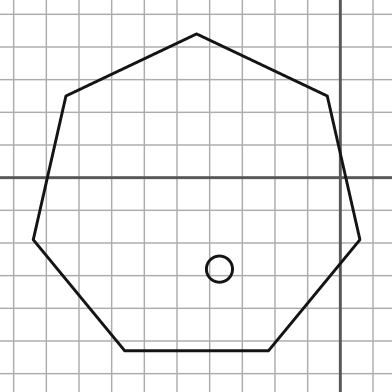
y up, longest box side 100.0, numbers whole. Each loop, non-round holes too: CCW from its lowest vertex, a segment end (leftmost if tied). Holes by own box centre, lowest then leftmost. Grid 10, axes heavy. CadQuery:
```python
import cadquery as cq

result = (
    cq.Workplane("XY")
    .moveTo(-66.0, -53.0)
    .lineTo(-22.0, -53.0)
    .lineTo(6.0, -19.0)
    .lineTo(-4.0, 25.0)
    .lineTo(-44.0, 44.0)
    .lineTo(-84.0, 25.0)
    .lineTo(-94.0, -19.0)
    .close()
    .moveTo(-37.0, -28.0)
    .circle(4.0)
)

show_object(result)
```